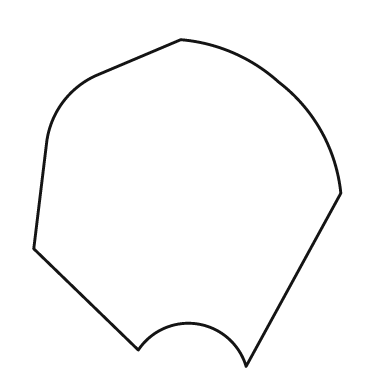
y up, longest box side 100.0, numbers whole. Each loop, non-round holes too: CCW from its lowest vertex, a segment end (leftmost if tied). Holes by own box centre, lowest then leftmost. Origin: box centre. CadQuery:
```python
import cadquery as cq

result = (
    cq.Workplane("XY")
    .moveTo(18.0, -50.0)
    .lineTo(47.0, 3.0)
    .threePointArc((41.0, 22.0), (28.0, 37.0))
    .threePointArc((14.0, 46.0), (-2.0, 50.0))
    .lineTo(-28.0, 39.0)
    .threePointArc((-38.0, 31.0), (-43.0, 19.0))
    .lineTo(-47.0, -14.0)
    .lineTo(-15.0, -45.0)
    .threePointArc((3.0, -37.0), (18.0, -50.0))
    .close()
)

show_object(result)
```